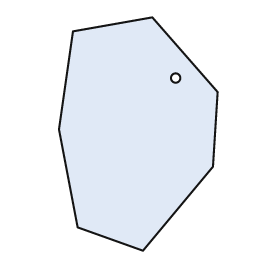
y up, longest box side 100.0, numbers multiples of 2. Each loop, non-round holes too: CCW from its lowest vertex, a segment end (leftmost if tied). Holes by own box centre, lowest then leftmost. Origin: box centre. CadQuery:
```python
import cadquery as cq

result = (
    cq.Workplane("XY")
    .moveTo(2.0, -50.0)
    .lineTo(32.0, -14.0)
    .lineTo(34.0, 18.0)
    .lineTo(6.0, 50.0)
    .lineTo(-28.0, 44.0)
    .lineTo(-34.0, 2.0)
    .lineTo(-26.0, -40.0)
    .close()
    .moveTo(16.0, 24.0)
    .circle(2.0)
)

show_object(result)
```